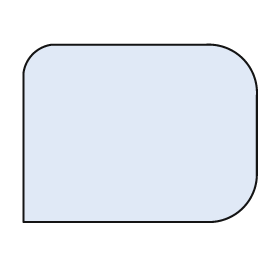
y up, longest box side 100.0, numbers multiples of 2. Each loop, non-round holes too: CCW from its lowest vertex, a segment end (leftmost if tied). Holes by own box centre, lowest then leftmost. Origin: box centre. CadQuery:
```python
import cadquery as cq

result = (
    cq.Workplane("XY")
    .moveTo(-50.0, -38.0)
    .lineTo(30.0, -38.0)
    .threePointArc((44.0, -32.0), (50.0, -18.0))
    .lineTo(50.0, 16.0)
    .threePointArc((44.0, 32.0), (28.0, 38.0))
    .lineTo(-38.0, 38.0)
    .threePointArc((-46.0, 34.0), (-50.0, 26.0))
    .close()
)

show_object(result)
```